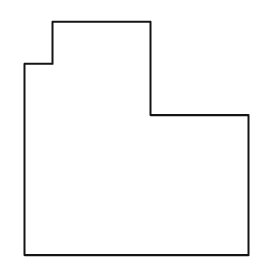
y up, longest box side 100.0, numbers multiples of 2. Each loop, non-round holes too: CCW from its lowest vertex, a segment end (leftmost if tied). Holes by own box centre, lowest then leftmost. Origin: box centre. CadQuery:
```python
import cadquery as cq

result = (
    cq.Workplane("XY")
    .moveTo(-48.0, -50.0)
    .lineTo(48.0, -50.0)
    .lineTo(48.0, 10.0)
    .lineTo(6.0, 10.0)
    .lineTo(6.0, 50.0)
    .lineTo(-36.0, 50.0)
    .lineTo(-36.0, 32.0)
    .lineTo(-48.0, 32.0)
    .close()
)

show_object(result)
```